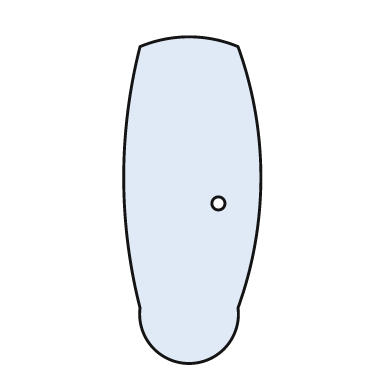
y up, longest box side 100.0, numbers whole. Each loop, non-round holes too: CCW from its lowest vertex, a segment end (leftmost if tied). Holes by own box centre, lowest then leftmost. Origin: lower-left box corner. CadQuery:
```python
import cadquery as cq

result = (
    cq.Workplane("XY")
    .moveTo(5.0, 17.0)
    .threePointArc((20.0, 0.0), (35.0, 17.0))
    .threePointArc((42.0, 57.0), (35.0, 97.0))
    .threePointArc((20.0, 100.0), (5.0, 97.0))
    .threePointArc((0.0, 57.0), (5.0, 17.0))
    .close()
    .moveTo(29.0, 49.0)
    .circle(2.0)
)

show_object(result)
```